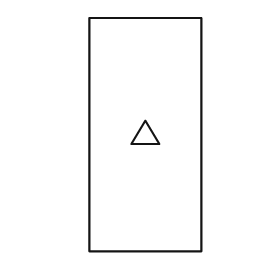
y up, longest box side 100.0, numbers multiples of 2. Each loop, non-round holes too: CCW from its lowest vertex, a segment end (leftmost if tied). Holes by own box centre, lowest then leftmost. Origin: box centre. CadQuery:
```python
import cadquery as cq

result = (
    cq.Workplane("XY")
    .moveTo(-24.0, -50.0)
    .lineTo(24.0, -50.0)
    .lineTo(24.0, 50.0)
    .lineTo(-24.0, 50.0)
    .close()
    .moveTo(-6.0, -4.0)
    .lineTo(6.0, -4.0)
    .lineTo(0.0, 6.0)
    .close()
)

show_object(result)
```